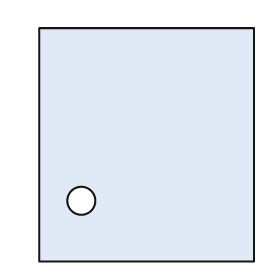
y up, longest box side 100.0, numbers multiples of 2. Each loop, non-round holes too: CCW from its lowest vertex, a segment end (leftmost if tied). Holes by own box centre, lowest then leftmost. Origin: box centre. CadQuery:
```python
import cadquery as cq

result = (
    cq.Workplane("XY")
    .moveTo(-46.0, -50.0)
    .lineTo(46.0, -50.0)
    .lineTo(46.0, 50.0)
    .lineTo(-46.0, 50.0)
    .close()
    .moveTo(-28.0, -24.0)
    .circle(6.0)
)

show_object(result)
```